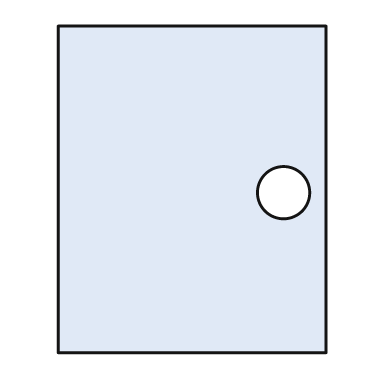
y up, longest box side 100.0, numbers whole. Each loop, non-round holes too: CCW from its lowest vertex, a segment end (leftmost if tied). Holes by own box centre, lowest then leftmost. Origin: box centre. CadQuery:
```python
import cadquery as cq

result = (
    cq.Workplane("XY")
    .moveTo(-41.0, -50.0)
    .lineTo(41.0, -50.0)
    .lineTo(41.0, 50.0)
    .lineTo(-41.0, 50.0)
    .close()
    .moveTo(28.0, -1.0)
    .circle(8.0)
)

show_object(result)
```